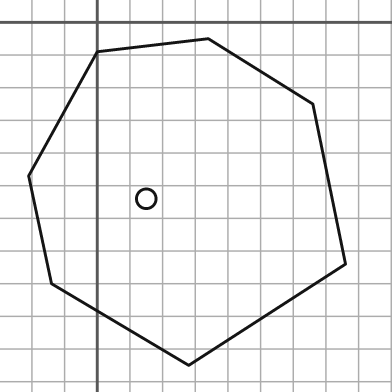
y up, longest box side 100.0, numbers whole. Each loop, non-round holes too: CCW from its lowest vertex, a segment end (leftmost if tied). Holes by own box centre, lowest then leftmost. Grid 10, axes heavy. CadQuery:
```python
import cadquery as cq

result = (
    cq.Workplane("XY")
    .moveTo(28.0, -105.0)
    .lineTo(76.0, -74.0)
    .lineTo(66.0, -25.0)
    .lineTo(34.0, -5.0)
    .lineTo(0.0, -9.0)
    .lineTo(-21.0, -47.0)
    .lineTo(-14.0, -80.0)
    .close()
    .moveTo(15.0, -54.0)
    .circle(3.0)
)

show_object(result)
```